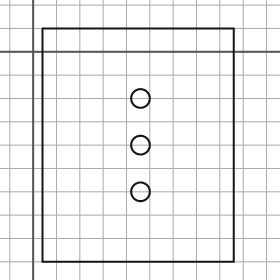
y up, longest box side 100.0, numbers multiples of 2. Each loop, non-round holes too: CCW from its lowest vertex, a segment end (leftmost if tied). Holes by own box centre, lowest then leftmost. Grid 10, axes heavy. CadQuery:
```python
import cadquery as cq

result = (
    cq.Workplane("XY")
    .moveTo(4.0, -90.0)
    .lineTo(86.0, -90.0)
    .lineTo(86.0, 10.0)
    .lineTo(4.0, 10.0)
    .close()
    .moveTo(46.0, -60.0)
    .circle(4.0)
    .moveTo(46.0, -40.0)
    .circle(4.0)
    .moveTo(46.0, -20.0)
    .circle(4.0)
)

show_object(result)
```